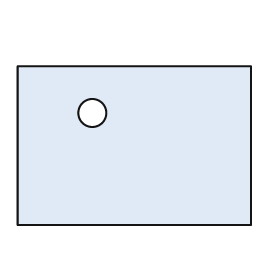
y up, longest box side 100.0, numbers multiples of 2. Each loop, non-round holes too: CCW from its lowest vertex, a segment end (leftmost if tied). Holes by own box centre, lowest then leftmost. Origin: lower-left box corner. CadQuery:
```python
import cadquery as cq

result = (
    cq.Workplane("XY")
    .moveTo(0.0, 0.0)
    .lineTo(100.0, 0.0)
    .lineTo(100.0, 68.0)
    .lineTo(0.0, 68.0)
    .close()
    .moveTo(32.0, 48.0)
    .circle(6.0)
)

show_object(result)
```